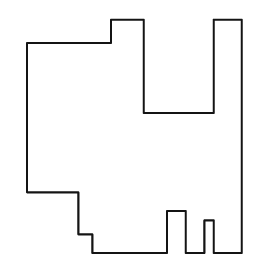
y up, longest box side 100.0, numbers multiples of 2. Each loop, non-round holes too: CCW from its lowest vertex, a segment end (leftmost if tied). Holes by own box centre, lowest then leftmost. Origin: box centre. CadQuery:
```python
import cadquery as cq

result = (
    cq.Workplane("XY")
    .moveTo(-18.0, -50.0)
    .lineTo(14.0, -50.0)
    .lineTo(14.0, -32.0)
    .lineTo(22.0, -32.0)
    .lineTo(22.0, -50.0)
    .lineTo(30.0, -50.0)
    .lineTo(30.0, -36.0)
    .lineTo(34.0, -36.0)
    .lineTo(34.0, -50.0)
    .lineTo(46.0, -50.0)
    .lineTo(46.0, 50.0)
    .lineTo(34.0, 50.0)
    .lineTo(34.0, 10.0)
    .lineTo(4.0, 10.0)
    .lineTo(4.0, 50.0)
    .lineTo(-10.0, 50.0)
    .lineTo(-10.0, 40.0)
    .lineTo(-46.0, 40.0)
    .lineTo(-46.0, -24.0)
    .lineTo(-24.0, -24.0)
    .lineTo(-24.0, -42.0)
    .lineTo(-18.0, -42.0)
    .close()
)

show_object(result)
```